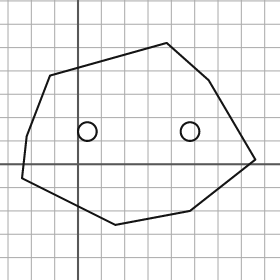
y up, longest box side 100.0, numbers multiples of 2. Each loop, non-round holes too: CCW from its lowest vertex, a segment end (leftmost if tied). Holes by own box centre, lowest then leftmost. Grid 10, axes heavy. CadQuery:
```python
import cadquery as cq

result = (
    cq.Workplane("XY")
    .moveTo(16.0, -26.0)
    .lineTo(48.0, -20.0)
    .lineTo(76.0, 2.0)
    .lineTo(56.0, 36.0)
    .lineTo(38.0, 52.0)
    .lineTo(-12.0, 38.0)
    .lineTo(-22.0, 12.0)
    .lineTo(-24.0, -6.0)
    .close()
    .moveTo(4.0, 14.0)
    .circle(4.0)
    .moveTo(48.0, 14.0)
    .circle(4.0)
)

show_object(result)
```